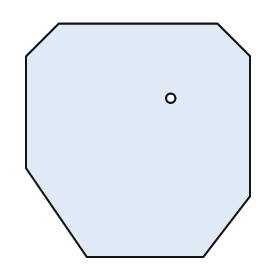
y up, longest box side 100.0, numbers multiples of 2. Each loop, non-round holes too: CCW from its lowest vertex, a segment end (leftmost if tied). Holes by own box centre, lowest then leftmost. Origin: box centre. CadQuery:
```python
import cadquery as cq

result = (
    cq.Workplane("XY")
    .moveTo(-22.0, -50.0)
    .lineTo(28.0, -50.0)
    .lineTo(48.0, -24.0)
    .lineTo(48.0, 36.0)
    .lineTo(34.0, 50.0)
    .lineTo(-34.0, 50.0)
    .lineTo(-48.0, 36.0)
    .lineTo(-48.0, -12.0)
    .close()
    .moveTo(14.0, 18.0)
    .circle(2.0)
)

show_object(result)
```